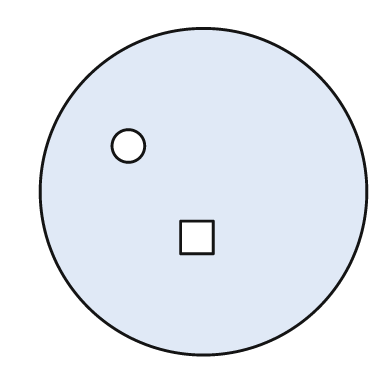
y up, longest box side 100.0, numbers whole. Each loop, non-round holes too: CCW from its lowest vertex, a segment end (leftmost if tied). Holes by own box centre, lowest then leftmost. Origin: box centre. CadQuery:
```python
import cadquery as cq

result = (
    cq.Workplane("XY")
    .moveTo(0.0, 0.0)
    .circle(50.0)
    .moveTo(-7.0, -19.0)
    .lineTo(3.0, -19.0)
    .lineTo(3.0, -9.0)
    .lineTo(-7.0, -9.0)
    .close()
    .moveTo(-23.0, 14.0)
    .circle(5.0)
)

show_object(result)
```